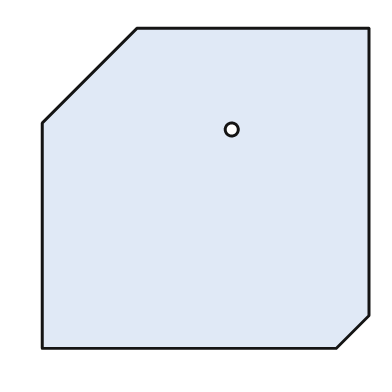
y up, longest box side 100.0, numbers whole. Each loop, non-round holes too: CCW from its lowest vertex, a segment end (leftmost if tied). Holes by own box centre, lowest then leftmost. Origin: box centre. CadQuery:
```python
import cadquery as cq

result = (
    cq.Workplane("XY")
    .moveTo(-50.0, -49.0)
    .lineTo(40.0, -49.0)
    .lineTo(50.0, -39.0)
    .lineTo(50.0, 49.0)
    .lineTo(-21.0, 49.0)
    .lineTo(-50.0, 20.0)
    .close()
    .moveTo(8.0, 18.0)
    .circle(2.0)
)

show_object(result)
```